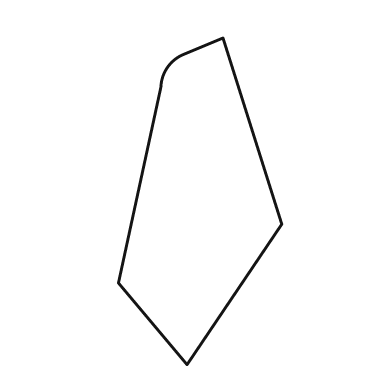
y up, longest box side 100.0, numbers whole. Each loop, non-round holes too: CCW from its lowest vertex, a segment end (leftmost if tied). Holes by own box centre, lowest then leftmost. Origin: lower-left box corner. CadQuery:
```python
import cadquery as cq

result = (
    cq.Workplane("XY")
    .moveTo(21.0, 0.0)
    .lineTo(50.0, 43.0)
    .lineTo(32.0, 100.0)
    .lineTo(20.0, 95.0)
    .threePointArc((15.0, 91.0), (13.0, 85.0))
    .lineTo(0.0, 25.0)
    .close()
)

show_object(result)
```